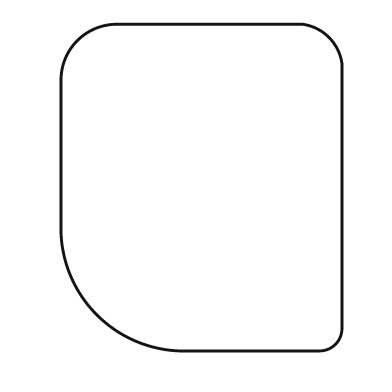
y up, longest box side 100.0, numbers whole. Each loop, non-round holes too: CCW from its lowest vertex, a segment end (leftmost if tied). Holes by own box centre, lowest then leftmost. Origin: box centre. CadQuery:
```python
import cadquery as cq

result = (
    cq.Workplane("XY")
    .moveTo(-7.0, -50.0)
    .lineTo(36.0, -50.0)
    .threePointArc((41.0, -48.0), (43.0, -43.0))
    .lineTo(43.0, 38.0)
    .threePointArc((39.0, 46.0), (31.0, 50.0))
    .lineTo(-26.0, 50.0)
    .threePointArc((-38.0, 45.0), (-43.0, 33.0))
    .lineTo(-43.0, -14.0)
    .threePointArc((-32.0, -39.0), (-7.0, -50.0))
    .close()
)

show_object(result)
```